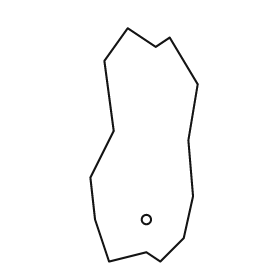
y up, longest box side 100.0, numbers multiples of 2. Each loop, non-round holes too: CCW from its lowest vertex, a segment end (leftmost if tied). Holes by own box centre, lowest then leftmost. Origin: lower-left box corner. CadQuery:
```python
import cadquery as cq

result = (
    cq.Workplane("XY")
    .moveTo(8.0, 0.0)
    .lineTo(24.0, 4.0)
    .lineTo(30.0, 0.0)
    .lineTo(40.0, 10.0)
    .lineTo(44.0, 28.0)
    .lineTo(42.0, 52.0)
    .lineTo(46.0, 76.0)
    .lineTo(34.0, 96.0)
    .lineTo(28.0, 92.0)
    .lineTo(16.0, 100.0)
    .lineTo(6.0, 86.0)
    .lineTo(10.0, 56.0)
    .lineTo(0.0, 36.0)
    .lineTo(2.0, 18.0)
    .close()
    .moveTo(24.0, 18.0)
    .circle(2.0)
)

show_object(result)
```